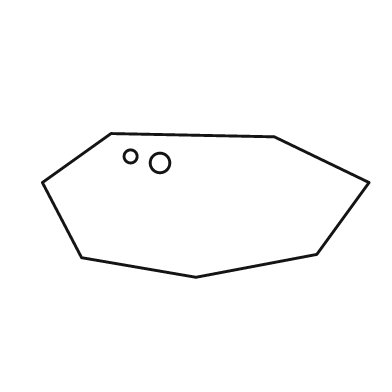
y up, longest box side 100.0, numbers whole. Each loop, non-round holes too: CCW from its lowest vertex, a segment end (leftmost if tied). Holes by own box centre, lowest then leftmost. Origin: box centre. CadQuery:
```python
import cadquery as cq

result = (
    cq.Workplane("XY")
    .moveTo(-3.0, -22.0)
    .lineTo(34.0, -15.0)
    .lineTo(50.0, 7.0)
    .lineTo(21.0, 21.0)
    .lineTo(-29.0, 22.0)
    .lineTo(-50.0, 7.0)
    .lineTo(-38.0, -16.0)
    .close()
    .moveTo(-14.0, 13.0)
    .circle(3.0)
    .moveTo(-23.0, 15.0)
    .circle(2.0)
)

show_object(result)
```